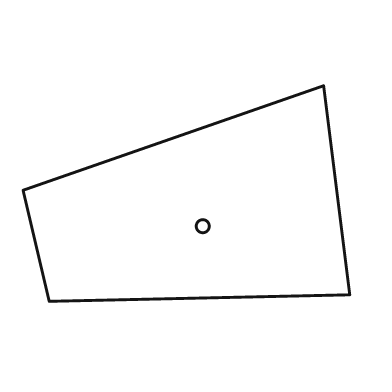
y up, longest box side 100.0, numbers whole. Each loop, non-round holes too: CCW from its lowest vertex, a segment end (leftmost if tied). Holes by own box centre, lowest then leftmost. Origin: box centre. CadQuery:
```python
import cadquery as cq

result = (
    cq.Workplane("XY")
    .moveTo(-42.0, -33.0)
    .lineTo(50.0, -31.0)
    .lineTo(42.0, 33.0)
    .lineTo(-50.0, 1.0)
    .close()
    .moveTo(5.0, -10.0)
    .circle(2.0)
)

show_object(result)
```